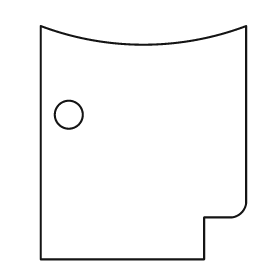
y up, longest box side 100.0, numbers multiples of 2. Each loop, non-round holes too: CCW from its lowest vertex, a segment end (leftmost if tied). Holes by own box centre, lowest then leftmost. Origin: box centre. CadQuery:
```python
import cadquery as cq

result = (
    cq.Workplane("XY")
    .moveTo(-44.0, -50.0)
    .lineTo(26.0, -50.0)
    .lineTo(26.0, -32.0)
    .lineTo(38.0, -32.0)
    .threePointArc((42.0, -30.0), (44.0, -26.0))
    .lineTo(44.0, 50.0)
    .threePointArc((0.0, 42.0), (-44.0, 50.0))
    .close()
    .moveTo(-32.0, 12.0)
    .circle(6.0)
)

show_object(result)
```